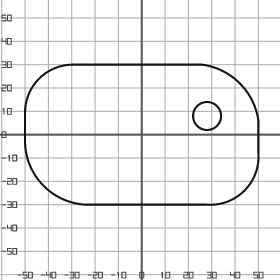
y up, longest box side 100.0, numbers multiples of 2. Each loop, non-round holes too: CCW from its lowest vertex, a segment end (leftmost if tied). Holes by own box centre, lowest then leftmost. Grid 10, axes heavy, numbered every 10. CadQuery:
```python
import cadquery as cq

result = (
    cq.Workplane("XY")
    .moveTo(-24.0, -30.0)
    .lineTo(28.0, -30.0)
    .threePointArc((44.0, -24.0), (50.0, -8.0))
    .lineTo(50.0, 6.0)
    .threePointArc((42.0, 22.0), (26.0, 30.0))
    .lineTo(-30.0, 30.0)
    .threePointArc((-44.0, 24.0), (-50.0, 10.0))
    .lineTo(-50.0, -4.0)
    .threePointArc((-42.0, -22.0), (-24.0, -30.0))
    .close()
    .moveTo(28.0, 8.0)
    .circle(6.0)
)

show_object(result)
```